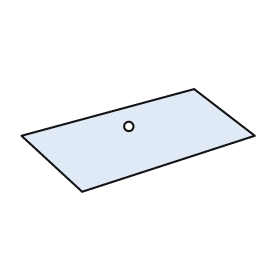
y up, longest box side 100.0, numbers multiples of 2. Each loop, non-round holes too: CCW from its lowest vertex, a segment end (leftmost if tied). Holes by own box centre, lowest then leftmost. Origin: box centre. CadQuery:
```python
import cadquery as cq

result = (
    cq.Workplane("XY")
    .moveTo(-24.0, -22.0)
    .lineTo(50.0, 2.0)
    .lineTo(24.0, 22.0)
    .lineTo(-50.0, 2.0)
    .close()
    .moveTo(-4.0, 6.0)
    .circle(2.0)
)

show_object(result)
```